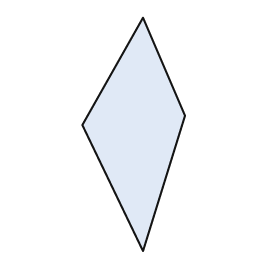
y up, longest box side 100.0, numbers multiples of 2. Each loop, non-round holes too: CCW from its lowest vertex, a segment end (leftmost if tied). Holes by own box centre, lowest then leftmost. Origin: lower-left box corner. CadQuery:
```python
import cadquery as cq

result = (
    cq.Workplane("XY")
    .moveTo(26.0, 0.0)
    .lineTo(44.0, 58.0)
    .lineTo(26.0, 100.0)
    .lineTo(0.0, 54.0)
    .close()
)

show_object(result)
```